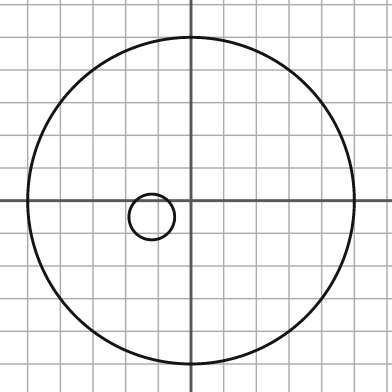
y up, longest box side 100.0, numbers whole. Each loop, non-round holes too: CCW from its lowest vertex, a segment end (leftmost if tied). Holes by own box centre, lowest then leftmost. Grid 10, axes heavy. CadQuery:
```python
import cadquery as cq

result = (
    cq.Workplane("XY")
    .moveTo(0.0, 0.0)
    .circle(50.0)
    .moveTo(-12.0, -5.0)
    .circle(7.0)
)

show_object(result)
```